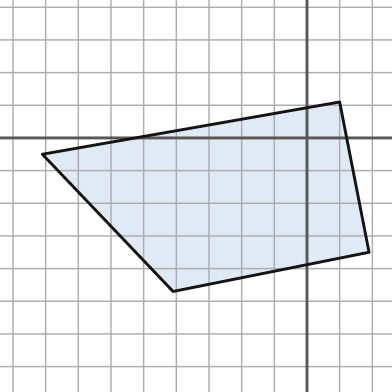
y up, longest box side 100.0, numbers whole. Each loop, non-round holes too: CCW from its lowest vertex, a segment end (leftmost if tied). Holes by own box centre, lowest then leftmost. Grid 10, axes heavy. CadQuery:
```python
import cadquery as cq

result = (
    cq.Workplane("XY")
    .moveTo(-41.0, -47.0)
    .lineTo(19.0, -35.0)
    .lineTo(10.0, 11.0)
    .lineTo(-81.0, -5.0)
    .close()
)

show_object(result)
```